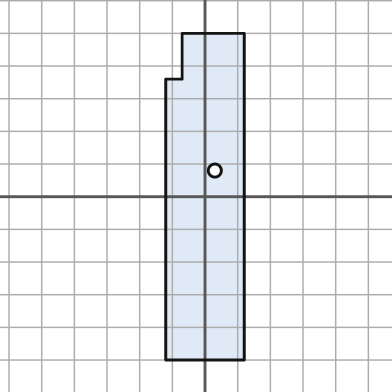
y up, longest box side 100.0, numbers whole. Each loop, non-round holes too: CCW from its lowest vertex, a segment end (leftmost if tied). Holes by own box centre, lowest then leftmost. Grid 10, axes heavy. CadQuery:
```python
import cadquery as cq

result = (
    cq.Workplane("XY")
    .moveTo(-12.0, -50.0)
    .lineTo(12.0, -50.0)
    .lineTo(12.0, 50.0)
    .lineTo(-7.0, 50.0)
    .lineTo(-7.0, 36.0)
    .lineTo(-12.0, 36.0)
    .close()
    .moveTo(3.0, 8.0)
    .circle(2.0)
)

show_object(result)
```